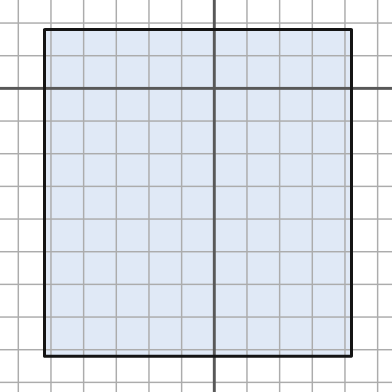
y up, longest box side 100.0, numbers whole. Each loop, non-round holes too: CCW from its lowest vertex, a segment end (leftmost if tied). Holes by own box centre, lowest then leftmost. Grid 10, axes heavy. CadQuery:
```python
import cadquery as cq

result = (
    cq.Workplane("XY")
    .moveTo(-52.0, -82.0)
    .lineTo(42.0, -82.0)
    .lineTo(42.0, 18.0)
    .lineTo(-52.0, 18.0)
    .close()
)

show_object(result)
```